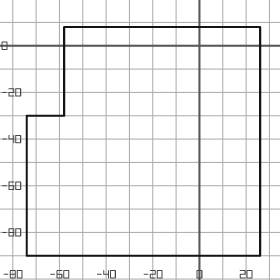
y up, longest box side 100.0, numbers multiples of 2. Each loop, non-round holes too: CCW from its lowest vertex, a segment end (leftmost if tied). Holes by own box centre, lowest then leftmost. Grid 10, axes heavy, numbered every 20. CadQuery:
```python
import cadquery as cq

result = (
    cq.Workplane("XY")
    .moveTo(-74.0, -90.0)
    .lineTo(26.0, -90.0)
    .lineTo(26.0, 8.0)
    .lineTo(-58.0, 8.0)
    .lineTo(-58.0, -30.0)
    .lineTo(-74.0, -30.0)
    .close()
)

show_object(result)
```